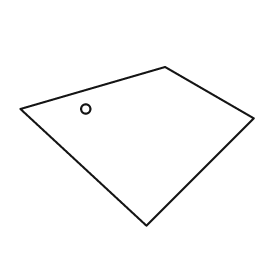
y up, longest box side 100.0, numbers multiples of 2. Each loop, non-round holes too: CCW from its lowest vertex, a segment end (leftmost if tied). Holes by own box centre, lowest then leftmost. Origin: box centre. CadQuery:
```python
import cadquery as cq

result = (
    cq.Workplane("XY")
    .moveTo(4.0, -34.0)
    .lineTo(50.0, 12.0)
    .lineTo(12.0, 34.0)
    .lineTo(-50.0, 16.0)
    .close()
    .moveTo(-22.0, 16.0)
    .circle(2.0)
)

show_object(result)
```